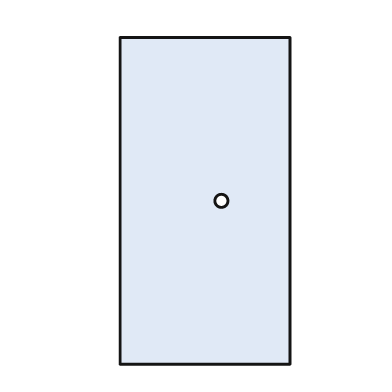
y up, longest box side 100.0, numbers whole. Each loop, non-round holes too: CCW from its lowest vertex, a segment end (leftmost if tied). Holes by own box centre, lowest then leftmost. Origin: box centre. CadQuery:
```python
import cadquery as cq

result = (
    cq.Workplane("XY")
    .moveTo(-26.0, -50.0)
    .lineTo(26.0, -50.0)
    .lineTo(26.0, 50.0)
    .lineTo(-26.0, 50.0)
    .close()
    .moveTo(5.0, 0.0)
    .circle(2.0)
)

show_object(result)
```